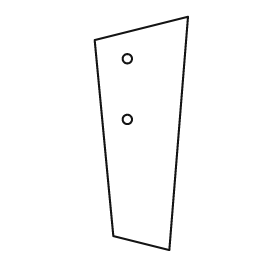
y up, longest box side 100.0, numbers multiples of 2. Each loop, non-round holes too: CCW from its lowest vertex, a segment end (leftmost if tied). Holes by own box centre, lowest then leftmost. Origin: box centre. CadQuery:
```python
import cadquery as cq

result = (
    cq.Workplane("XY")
    .moveTo(12.0, -50.0)
    .lineTo(20.0, 50.0)
    .lineTo(-20.0, 40.0)
    .lineTo(-12.0, -44.0)
    .close()
    .moveTo(-6.0, 6.0)
    .circle(2.0)
    .moveTo(-6.0, 32.0)
    .circle(2.0)
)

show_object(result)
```